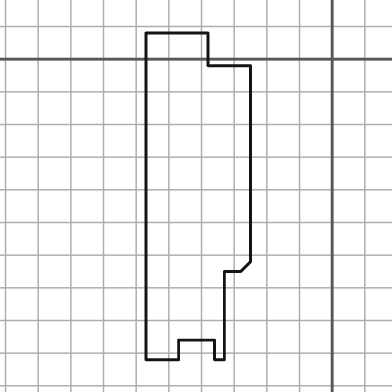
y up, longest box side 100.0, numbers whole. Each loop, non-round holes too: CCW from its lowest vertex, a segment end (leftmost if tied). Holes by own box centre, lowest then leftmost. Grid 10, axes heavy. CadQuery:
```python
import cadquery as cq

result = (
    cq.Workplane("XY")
    .moveTo(-57.0, -92.0)
    .lineTo(-47.0, -92.0)
    .lineTo(-47.0, -86.0)
    .lineTo(-36.0, -86.0)
    .lineTo(-36.0, -92.0)
    .lineTo(-33.0, -92.0)
    .lineTo(-33.0, -65.0)
    .lineTo(-28.0, -65.0)
    .lineTo(-25.0, -62.0)
    .lineTo(-25.0, -2.0)
    .lineTo(-38.0, -2.0)
    .lineTo(-38.0, 8.0)
    .lineTo(-57.0, 8.0)
    .close()
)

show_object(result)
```